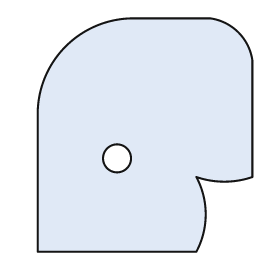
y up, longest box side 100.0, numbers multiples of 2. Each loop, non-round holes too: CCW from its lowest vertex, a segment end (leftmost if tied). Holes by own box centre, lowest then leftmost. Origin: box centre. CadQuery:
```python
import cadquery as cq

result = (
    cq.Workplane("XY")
    .moveTo(-46.0, -50.0)
    .lineTo(22.0, -50.0)
    .threePointArc((26.0, -34.0), (22.0, -18.0))
    .threePointArc((34.0, -20.0), (46.0, -18.0))
    .lineTo(46.0, 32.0)
    .threePointArc((40.0, 44.0), (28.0, 50.0))
    .lineTo(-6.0, 50.0)
    .threePointArc((-34.0, 38.0), (-46.0, 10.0))
    .close()
    .moveTo(-12.0, -10.0)
    .circle(6.0)
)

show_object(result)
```